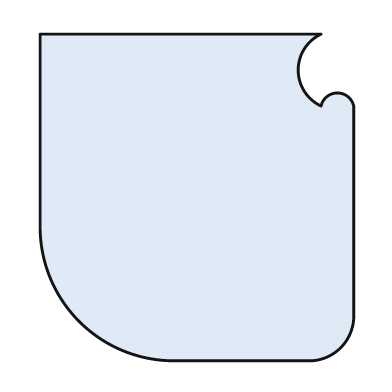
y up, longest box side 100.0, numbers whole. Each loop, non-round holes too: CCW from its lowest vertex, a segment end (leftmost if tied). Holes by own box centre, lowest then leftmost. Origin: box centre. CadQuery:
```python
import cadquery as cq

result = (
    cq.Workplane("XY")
    .moveTo(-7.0, -50.0)
    .lineTo(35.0, -50.0)
    .threePointArc((44.0, -46.0), (48.0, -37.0))
    .lineTo(48.0, 28.0)
    .threePointArc((43.0, 32.0), (38.0, 28.0))
    .threePointArc((31.0, 39.0), (38.0, 50.0))
    .lineTo(-48.0, 50.0)
    .lineTo(-48.0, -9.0)
    .threePointArc((-36.0, -38.0), (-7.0, -50.0))
    .close()
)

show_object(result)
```